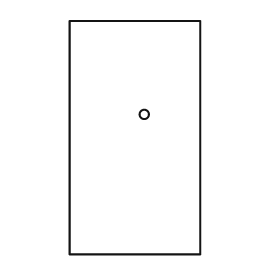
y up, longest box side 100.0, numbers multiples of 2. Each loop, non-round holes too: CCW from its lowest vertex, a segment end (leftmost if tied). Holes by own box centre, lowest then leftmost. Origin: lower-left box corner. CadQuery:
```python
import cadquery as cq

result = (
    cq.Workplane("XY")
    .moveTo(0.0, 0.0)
    .lineTo(56.0, 0.0)
    .lineTo(56.0, 100.0)
    .lineTo(0.0, 100.0)
    .close()
    .moveTo(32.0, 60.0)
    .circle(2.0)
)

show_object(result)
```